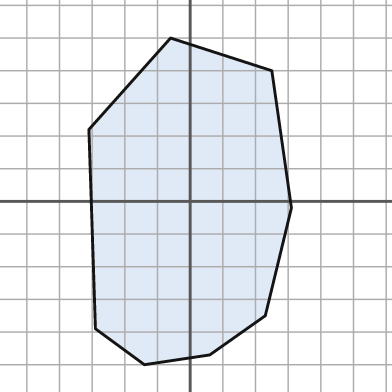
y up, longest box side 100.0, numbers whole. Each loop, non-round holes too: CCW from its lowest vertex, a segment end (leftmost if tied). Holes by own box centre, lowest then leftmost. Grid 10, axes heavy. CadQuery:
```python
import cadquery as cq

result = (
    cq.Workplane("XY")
    .moveTo(-14.0, -50.0)
    .lineTo(6.0, -47.0)
    .lineTo(23.0, -35.0)
    .lineTo(31.0, -2.0)
    .lineTo(25.0, 40.0)
    .lineTo(-6.0, 50.0)
    .lineTo(-31.0, 22.0)
    .lineTo(-29.0, -39.0)
    .close()
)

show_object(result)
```